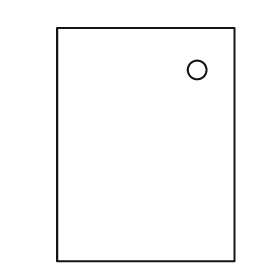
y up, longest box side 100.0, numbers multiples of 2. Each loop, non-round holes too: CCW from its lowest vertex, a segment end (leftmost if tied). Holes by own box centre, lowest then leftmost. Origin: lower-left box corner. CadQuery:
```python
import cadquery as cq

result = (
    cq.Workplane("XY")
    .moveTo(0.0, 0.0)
    .lineTo(76.0, 0.0)
    .lineTo(76.0, 100.0)
    .lineTo(0.0, 100.0)
    .close()
    .moveTo(60.0, 82.0)
    .circle(4.0)
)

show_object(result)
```